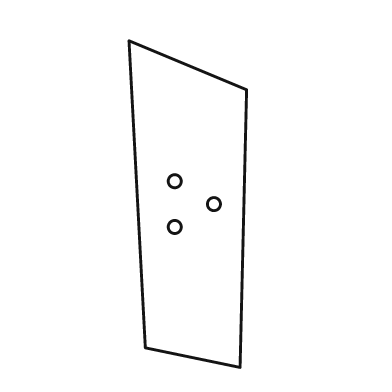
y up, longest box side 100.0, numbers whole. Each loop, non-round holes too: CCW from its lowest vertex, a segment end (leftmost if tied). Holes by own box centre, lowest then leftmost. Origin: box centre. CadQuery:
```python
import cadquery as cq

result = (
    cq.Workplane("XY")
    .moveTo(16.0, -50.0)
    .lineTo(18.0, 35.0)
    .lineTo(-18.0, 50.0)
    .lineTo(-13.0, -44.0)
    .close()
    .moveTo(-4.0, -7.0)
    .circle(2.0)
    .moveTo(8.0, 0.0)
    .circle(2.0)
    .moveTo(-4.0, 7.0)
    .circle(2.0)
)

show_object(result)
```